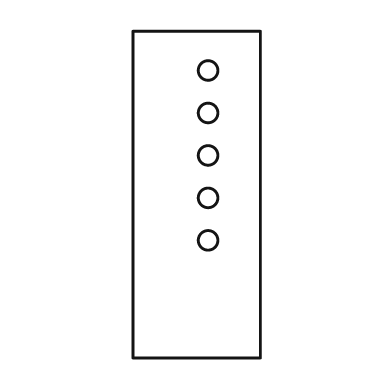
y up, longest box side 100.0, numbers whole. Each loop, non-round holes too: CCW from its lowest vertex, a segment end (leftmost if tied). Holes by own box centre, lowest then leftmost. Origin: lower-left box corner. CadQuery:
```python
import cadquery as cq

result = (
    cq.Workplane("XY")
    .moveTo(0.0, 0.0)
    .lineTo(39.0, 0.0)
    .lineTo(39.0, 100.0)
    .lineTo(0.0, 100.0)
    .close()
    .moveTo(23.0, 36.0)
    .circle(3.0)
    .moveTo(23.0, 49.0)
    .circle(3.0)
    .moveTo(23.0, 62.0)
    .circle(3.0)
    .moveTo(23.0, 75.0)
    .circle(3.0)
    .moveTo(23.0, 88.0)
    .circle(3.0)
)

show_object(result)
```